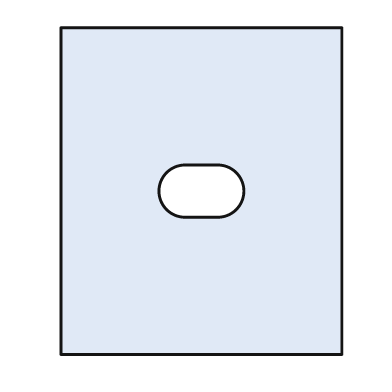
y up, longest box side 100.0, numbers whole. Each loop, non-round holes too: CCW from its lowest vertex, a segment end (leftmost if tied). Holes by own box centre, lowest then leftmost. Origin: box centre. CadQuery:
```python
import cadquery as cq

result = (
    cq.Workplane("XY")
    .moveTo(-43.0, -50.0)
    .lineTo(43.0, -50.0)
    .lineTo(43.0, 50.0)
    .lineTo(-43.0, 50.0)
    .close()
    .moveTo(-5.0, -8.0)
    .lineTo(5.0, -8.0)
    .threePointArc((13.0, 0.0), (5.0, 8.0))
    .lineTo(-5.0, 8.0)
    .threePointArc((-13.0, 0.0), (-5.0, -8.0))
    .close()
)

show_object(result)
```